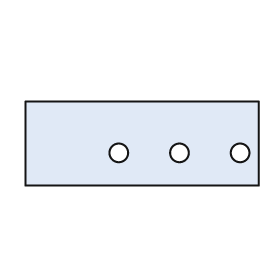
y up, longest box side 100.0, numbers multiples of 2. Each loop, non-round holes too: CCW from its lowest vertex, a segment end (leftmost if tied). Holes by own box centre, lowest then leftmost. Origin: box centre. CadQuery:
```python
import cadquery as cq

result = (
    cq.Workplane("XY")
    .moveTo(-50.0, -18.0)
    .lineTo(50.0, -18.0)
    .lineTo(50.0, 18.0)
    .lineTo(-50.0, 18.0)
    .close()
    .moveTo(-10.0, -4.0)
    .circle(4.0)
    .moveTo(16.0, -4.0)
    .circle(4.0)
    .moveTo(42.0, -4.0)
    .circle(4.0)
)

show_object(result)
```